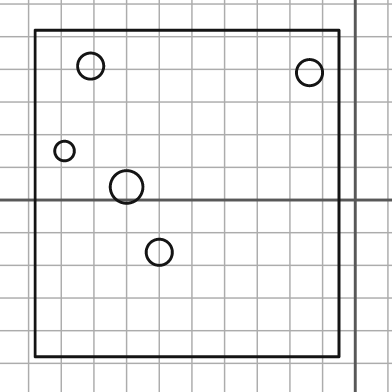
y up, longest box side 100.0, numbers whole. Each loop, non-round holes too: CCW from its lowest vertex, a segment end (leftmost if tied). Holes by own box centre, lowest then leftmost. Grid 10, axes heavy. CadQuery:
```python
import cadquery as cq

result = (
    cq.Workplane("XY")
    .moveTo(-98.0, -48.0)
    .lineTo(-5.0, -48.0)
    .lineTo(-5.0, 52.0)
    .lineTo(-98.0, 52.0)
    .close()
    .moveTo(-60.0, -16.0)
    .circle(4.0)
    .moveTo(-70.0, 4.0)
    .circle(5.0)
    .moveTo(-89.0, 15.0)
    .circle(3.0)
    .moveTo(-14.0, 39.0)
    .circle(4.0)
    .moveTo(-81.0, 41.0)
    .circle(4.0)
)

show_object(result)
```